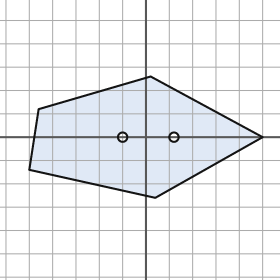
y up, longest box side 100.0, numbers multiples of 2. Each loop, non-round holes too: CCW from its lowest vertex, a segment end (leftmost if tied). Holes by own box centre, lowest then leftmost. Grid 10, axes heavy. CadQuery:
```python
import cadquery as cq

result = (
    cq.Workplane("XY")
    .moveTo(4.0, -26.0)
    .lineTo(50.0, 0.0)
    .lineTo(2.0, 26.0)
    .lineTo(-46.0, 12.0)
    .lineTo(-50.0, -14.0)
    .close()
    .moveTo(-10.0, 0.0)
    .circle(2.0)
    .moveTo(12.0, 0.0)
    .circle(2.0)
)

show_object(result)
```